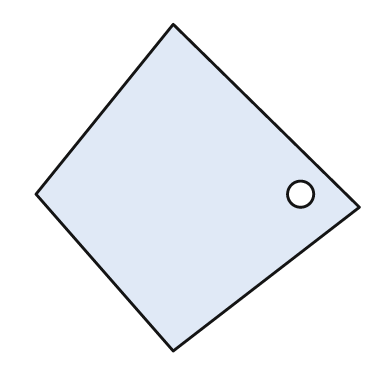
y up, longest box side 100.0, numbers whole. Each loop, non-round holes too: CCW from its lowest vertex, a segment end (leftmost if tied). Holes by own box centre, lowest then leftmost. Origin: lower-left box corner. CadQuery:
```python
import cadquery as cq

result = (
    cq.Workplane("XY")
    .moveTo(42.0, 0.0)
    .lineTo(99.0, 44.0)
    .lineTo(42.0, 100.0)
    .lineTo(0.0, 48.0)
    .close()
    .moveTo(81.0, 48.0)
    .circle(4.0)
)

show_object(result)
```